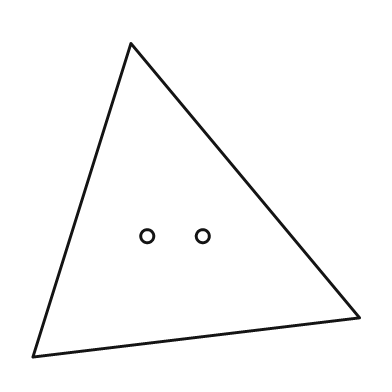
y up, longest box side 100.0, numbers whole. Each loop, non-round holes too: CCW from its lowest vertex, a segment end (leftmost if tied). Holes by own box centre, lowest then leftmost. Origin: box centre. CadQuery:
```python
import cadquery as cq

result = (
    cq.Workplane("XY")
    .moveTo(-50.0, -48.0)
    .lineTo(50.0, -36.0)
    .lineTo(-20.0, 48.0)
    .close()
    .moveTo(-15.0, -11.0)
    .circle(2.0)
    .moveTo(2.0, -11.0)
    .circle(2.0)
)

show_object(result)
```